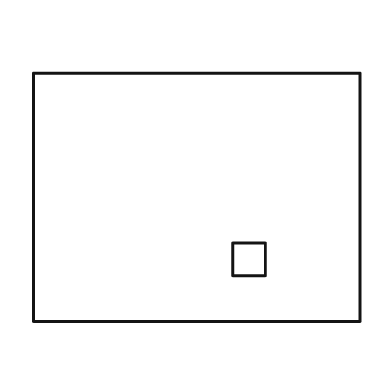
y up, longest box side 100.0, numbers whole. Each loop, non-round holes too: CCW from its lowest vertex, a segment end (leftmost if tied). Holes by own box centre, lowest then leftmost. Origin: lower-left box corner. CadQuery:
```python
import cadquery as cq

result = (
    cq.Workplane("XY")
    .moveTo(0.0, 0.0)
    .lineTo(100.0, 0.0)
    .lineTo(100.0, 76.0)
    .lineTo(0.0, 76.0)
    .close()
    .moveTo(61.0, 14.0)
    .lineTo(71.0, 14.0)
    .lineTo(71.0, 24.0)
    .lineTo(61.0, 24.0)
    .close()
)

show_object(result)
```